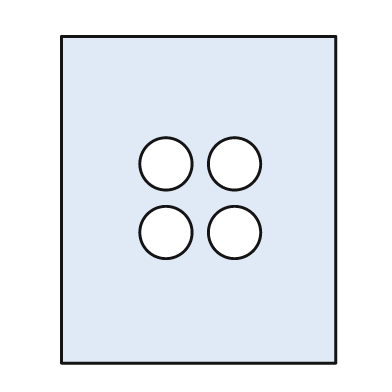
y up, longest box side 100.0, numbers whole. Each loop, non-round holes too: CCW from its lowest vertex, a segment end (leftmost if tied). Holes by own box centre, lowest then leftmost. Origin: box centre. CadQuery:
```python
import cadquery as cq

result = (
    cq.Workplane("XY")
    .moveTo(-42.0, -50.0)
    .lineTo(42.0, -50.0)
    .lineTo(42.0, 50.0)
    .lineTo(-42.0, 50.0)
    .close()
    .moveTo(-10.0, -10.0)
    .circle(8.0)
    .moveTo(11.0, -10.0)
    .circle(8.0)
    .moveTo(-10.0, 11.0)
    .circle(8.0)
    .moveTo(11.0, 11.0)
    .circle(8.0)
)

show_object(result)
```